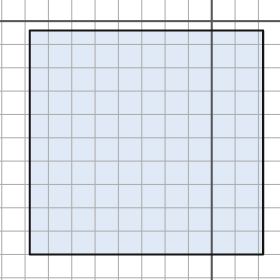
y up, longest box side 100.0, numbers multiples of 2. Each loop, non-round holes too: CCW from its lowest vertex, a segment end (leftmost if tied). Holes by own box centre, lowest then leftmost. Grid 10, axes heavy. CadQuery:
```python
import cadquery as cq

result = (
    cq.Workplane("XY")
    .moveTo(-78.0, -100.0)
    .lineTo(22.0, -100.0)
    .lineTo(22.0, -4.0)
    .lineTo(-78.0, -4.0)
    .close()
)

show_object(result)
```